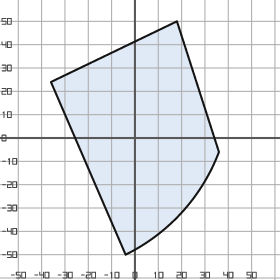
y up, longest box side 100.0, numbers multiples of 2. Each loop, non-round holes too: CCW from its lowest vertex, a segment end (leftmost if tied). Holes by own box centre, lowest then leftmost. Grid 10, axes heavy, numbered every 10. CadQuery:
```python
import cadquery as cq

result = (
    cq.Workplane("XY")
    .moveTo(-4.0, -50.0)
    .threePointArc((20.0, -32.0), (36.0, -6.0))
    .lineTo(18.0, 50.0)
    .lineTo(-36.0, 24.0)
    .close()
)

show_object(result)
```